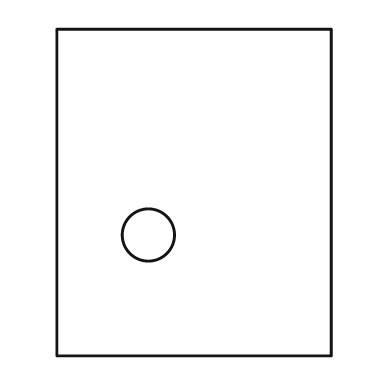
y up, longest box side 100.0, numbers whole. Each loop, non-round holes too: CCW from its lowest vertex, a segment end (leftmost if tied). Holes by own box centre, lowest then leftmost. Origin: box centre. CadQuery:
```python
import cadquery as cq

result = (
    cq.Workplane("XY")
    .moveTo(-42.0, -50.0)
    .lineTo(42.0, -50.0)
    .lineTo(42.0, 50.0)
    .lineTo(-42.0, 50.0)
    .close()
    .moveTo(-14.0, -13.0)
    .circle(8.0)
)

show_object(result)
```